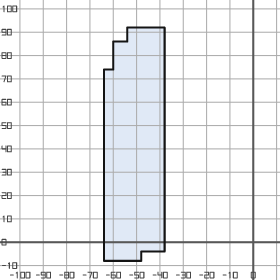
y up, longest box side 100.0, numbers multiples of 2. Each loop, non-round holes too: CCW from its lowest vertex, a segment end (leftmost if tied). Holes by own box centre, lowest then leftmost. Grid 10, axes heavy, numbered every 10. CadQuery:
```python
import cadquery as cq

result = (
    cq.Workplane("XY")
    .moveTo(-64.0, -8.0)
    .lineTo(-48.0, -8.0)
    .lineTo(-48.0, -4.0)
    .lineTo(-38.0, -4.0)
    .lineTo(-38.0, 92.0)
    .lineTo(-54.0, 92.0)
    .lineTo(-54.0, 86.0)
    .lineTo(-60.0, 86.0)
    .lineTo(-60.0, 74.0)
    .lineTo(-64.0, 74.0)
    .close()
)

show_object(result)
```